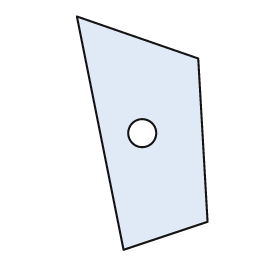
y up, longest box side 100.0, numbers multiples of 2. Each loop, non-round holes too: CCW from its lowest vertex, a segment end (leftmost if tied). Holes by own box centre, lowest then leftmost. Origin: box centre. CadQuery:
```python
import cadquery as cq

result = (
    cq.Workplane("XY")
    .moveTo(-8.0, -50.0)
    .lineTo(28.0, -38.0)
    .lineTo(24.0, 32.0)
    .lineTo(-28.0, 50.0)
    .close()
    .moveTo(0.0, 0.0)
    .circle(6.0)
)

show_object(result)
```